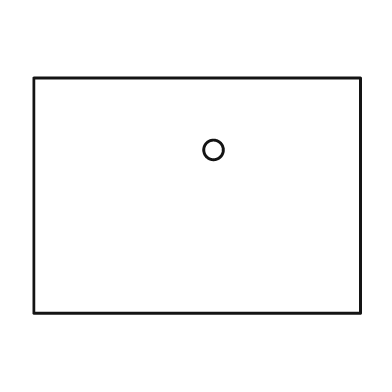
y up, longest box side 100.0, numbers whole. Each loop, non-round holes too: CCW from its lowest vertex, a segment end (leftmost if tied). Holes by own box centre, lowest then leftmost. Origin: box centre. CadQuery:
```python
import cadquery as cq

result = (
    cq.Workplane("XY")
    .moveTo(-50.0, -36.0)
    .lineTo(50.0, -36.0)
    .lineTo(50.0, 36.0)
    .lineTo(-50.0, 36.0)
    .close()
    .moveTo(5.0, 14.0)
    .circle(3.0)
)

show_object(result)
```